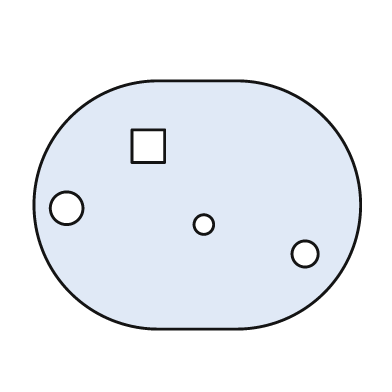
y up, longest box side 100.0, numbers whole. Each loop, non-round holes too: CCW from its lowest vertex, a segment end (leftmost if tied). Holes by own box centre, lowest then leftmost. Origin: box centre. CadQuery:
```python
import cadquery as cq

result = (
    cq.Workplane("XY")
    .moveTo(-12.0, -38.0)
    .lineTo(12.0, -38.0)
    .threePointArc((50.0, 0.0), (12.0, 38.0))
    .lineTo(-12.0, 38.0)
    .threePointArc((-50.0, 0.0), (-12.0, -38.0))
    .close()
    .moveTo(33.0, -15.0)
    .circle(4.0)
    .moveTo(2.0, -6.0)
    .circle(3.0)
    .moveTo(-40.0, -1.0)
    .circle(5.0)
    .moveTo(-20.0, 13.0)
    .lineTo(-10.0, 13.0)
    .lineTo(-10.0, 23.0)
    .lineTo(-20.0, 23.0)
    .close()
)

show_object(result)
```